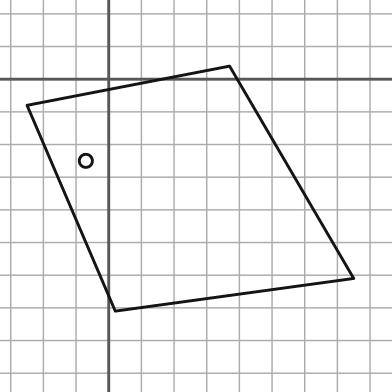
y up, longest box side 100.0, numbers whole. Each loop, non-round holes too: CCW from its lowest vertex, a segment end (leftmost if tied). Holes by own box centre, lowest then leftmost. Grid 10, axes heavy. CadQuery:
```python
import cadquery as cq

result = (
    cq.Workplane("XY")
    .moveTo(2.0, -71.0)
    .lineTo(75.0, -61.0)
    .lineTo(37.0, 4.0)
    .lineTo(-25.0, -8.0)
    .close()
    .moveTo(-7.0, -25.0)
    .circle(2.0)
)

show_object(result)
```